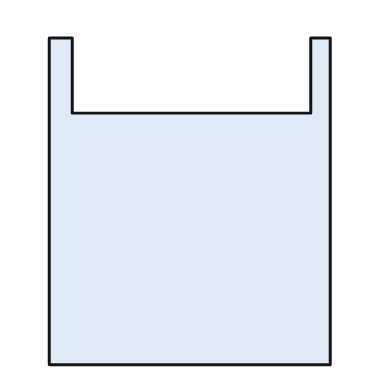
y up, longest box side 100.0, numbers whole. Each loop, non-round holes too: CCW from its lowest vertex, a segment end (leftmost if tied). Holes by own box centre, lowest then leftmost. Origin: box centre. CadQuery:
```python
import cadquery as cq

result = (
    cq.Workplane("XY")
    .moveTo(-43.0, -50.0)
    .lineTo(43.0, -50.0)
    .lineTo(43.0, 50.0)
    .lineTo(37.0, 50.0)
    .lineTo(37.0, 27.0)
    .lineTo(-36.0, 27.0)
    .lineTo(-36.0, 50.0)
    .lineTo(-43.0, 50.0)
    .close()
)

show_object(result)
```